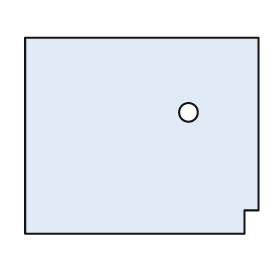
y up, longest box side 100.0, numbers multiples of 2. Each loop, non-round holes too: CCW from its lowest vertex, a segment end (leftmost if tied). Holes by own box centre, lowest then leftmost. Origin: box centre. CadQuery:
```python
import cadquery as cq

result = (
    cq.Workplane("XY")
    .moveTo(-50.0, -42.0)
    .lineTo(44.0, -42.0)
    .lineTo(44.0, -32.0)
    .lineTo(50.0, -32.0)
    .lineTo(50.0, 42.0)
    .lineTo(-50.0, 42.0)
    .close()
    .moveTo(20.0, 10.0)
    .circle(4.0)
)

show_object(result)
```